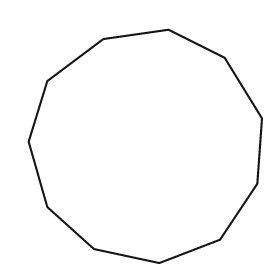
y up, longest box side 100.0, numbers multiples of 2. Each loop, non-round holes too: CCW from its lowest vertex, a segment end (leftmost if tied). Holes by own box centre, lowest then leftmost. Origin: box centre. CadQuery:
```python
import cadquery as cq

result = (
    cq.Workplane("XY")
    .moveTo(6.0, -50.0)
    .lineTo(32.0, -40.0)
    .lineTo(48.0, -16.0)
    .lineTo(50.0, 12.0)
    .lineTo(34.0, 38.0)
    .lineTo(10.0, 50.0)
    .lineTo(-18.0, 46.0)
    .lineTo(-42.0, 28.0)
    .lineTo(-50.0, 2.0)
    .lineTo(-42.0, -26.0)
    .lineTo(-22.0, -44.0)
    .close()
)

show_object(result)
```